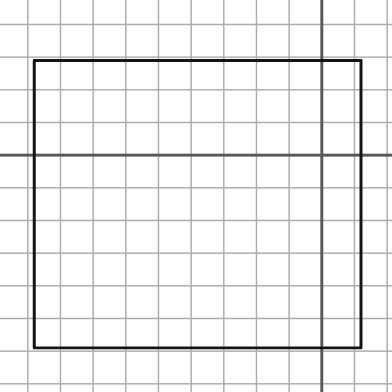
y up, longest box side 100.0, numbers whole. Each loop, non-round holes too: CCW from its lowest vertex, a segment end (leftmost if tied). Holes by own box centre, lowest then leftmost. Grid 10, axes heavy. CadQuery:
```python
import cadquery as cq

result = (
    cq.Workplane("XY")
    .moveTo(-88.0, -59.0)
    .lineTo(12.0, -59.0)
    .lineTo(12.0, 29.0)
    .lineTo(-88.0, 29.0)
    .close()
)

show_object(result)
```